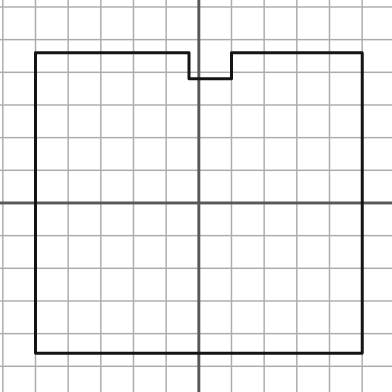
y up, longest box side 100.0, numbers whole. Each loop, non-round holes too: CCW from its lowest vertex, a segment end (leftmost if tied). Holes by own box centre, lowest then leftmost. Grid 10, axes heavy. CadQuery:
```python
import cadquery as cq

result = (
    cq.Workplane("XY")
    .moveTo(-50.0, -46.0)
    .lineTo(50.0, -46.0)
    .lineTo(50.0, 46.0)
    .lineTo(10.0, 46.0)
    .lineTo(10.0, 38.0)
    .lineTo(-3.0, 38.0)
    .lineTo(-3.0, 46.0)
    .lineTo(-50.0, 46.0)
    .close()
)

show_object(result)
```